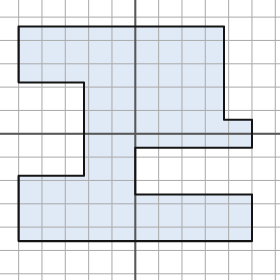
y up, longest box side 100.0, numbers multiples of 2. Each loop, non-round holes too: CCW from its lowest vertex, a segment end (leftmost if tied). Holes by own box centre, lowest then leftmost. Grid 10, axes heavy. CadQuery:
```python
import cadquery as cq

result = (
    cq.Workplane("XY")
    .moveTo(-50.0, -46.0)
    .lineTo(50.0, -46.0)
    .lineTo(50.0, -26.0)
    .lineTo(0.0, -26.0)
    .lineTo(0.0, -6.0)
    .lineTo(50.0, -6.0)
    .lineTo(50.0, 6.0)
    .lineTo(38.0, 6.0)
    .lineTo(38.0, 46.0)
    .lineTo(-50.0, 46.0)
    .lineTo(-50.0, 22.0)
    .lineTo(-22.0, 22.0)
    .lineTo(-22.0, -18.0)
    .lineTo(-50.0, -18.0)
    .close()
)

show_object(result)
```